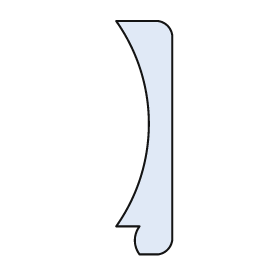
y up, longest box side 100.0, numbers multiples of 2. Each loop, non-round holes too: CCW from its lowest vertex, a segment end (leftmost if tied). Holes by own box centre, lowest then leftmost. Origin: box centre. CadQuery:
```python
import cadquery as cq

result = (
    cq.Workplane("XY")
    .moveTo(-2.0, -50.0)
    .lineTo(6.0, -50.0)
    .threePointArc((10.0, -48.0), (12.0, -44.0))
    .lineTo(12.0, 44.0)
    .threePointArc((10.0, 48.0), (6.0, 50.0))
    .lineTo(-12.0, 50.0)
    .threePointArc((2.0, 6.0), (-12.0, -38.0))
    .lineTo(-2.0, -38.0)
    .threePointArc((-4.0, -44.0), (-2.0, -50.0))
    .close()
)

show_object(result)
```